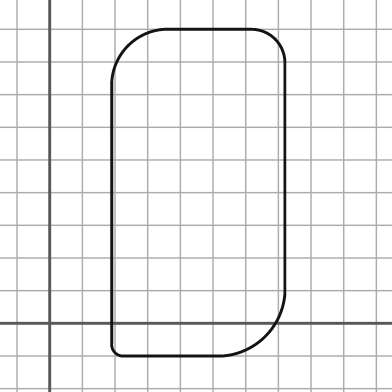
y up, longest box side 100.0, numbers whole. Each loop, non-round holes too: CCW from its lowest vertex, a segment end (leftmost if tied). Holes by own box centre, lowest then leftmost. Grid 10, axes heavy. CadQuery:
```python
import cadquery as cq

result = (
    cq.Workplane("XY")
    .moveTo(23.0, -10.0)
    .lineTo(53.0, -10.0)
    .threePointArc((66.0, -4.0), (72.0, 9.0))
    .lineTo(72.0, 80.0)
    .threePointArc((69.0, 87.0), (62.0, 90.0))
    .lineTo(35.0, 90.0)
    .threePointArc((24.0, 85.0), (19.0, 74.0))
    .lineTo(19.0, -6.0)
    .threePointArc((20.0, -9.0), (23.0, -10.0))
    .close()
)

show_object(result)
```